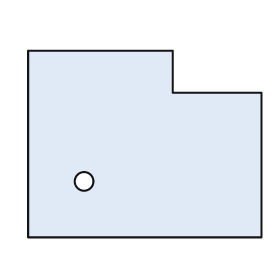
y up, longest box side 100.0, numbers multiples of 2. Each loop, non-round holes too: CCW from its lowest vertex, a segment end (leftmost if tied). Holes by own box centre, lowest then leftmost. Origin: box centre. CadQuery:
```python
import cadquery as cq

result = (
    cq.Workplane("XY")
    .moveTo(-50.0, -40.0)
    .lineTo(50.0, -40.0)
    .lineTo(50.0, 22.0)
    .lineTo(12.0, 22.0)
    .lineTo(12.0, 40.0)
    .lineTo(-50.0, 40.0)
    .close()
    .moveTo(-26.0, -16.0)
    .circle(4.0)
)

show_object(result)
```